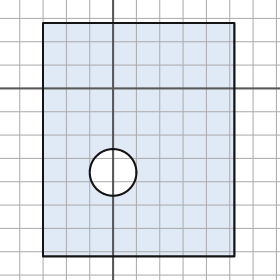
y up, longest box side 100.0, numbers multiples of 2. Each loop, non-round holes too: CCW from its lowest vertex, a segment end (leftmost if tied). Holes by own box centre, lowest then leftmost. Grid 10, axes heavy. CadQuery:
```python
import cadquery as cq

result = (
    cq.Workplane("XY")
    .moveTo(-30.0, -72.0)
    .lineTo(52.0, -72.0)
    .lineTo(52.0, 28.0)
    .lineTo(-30.0, 28.0)
    .close()
    .moveTo(0.0, -36.0)
    .circle(10.0)
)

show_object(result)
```